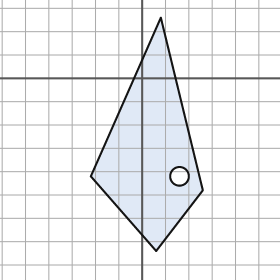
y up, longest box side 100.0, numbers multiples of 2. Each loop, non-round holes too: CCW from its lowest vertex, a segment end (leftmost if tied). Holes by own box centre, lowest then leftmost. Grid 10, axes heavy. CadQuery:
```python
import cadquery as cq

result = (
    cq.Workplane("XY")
    .moveTo(6.0, -74.0)
    .lineTo(26.0, -48.0)
    .lineTo(8.0, 26.0)
    .lineTo(-22.0, -42.0)
    .close()
    .moveTo(16.0, -42.0)
    .circle(4.0)
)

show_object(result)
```